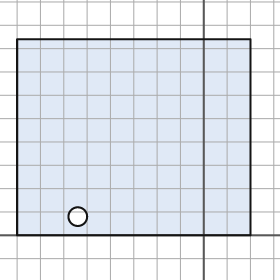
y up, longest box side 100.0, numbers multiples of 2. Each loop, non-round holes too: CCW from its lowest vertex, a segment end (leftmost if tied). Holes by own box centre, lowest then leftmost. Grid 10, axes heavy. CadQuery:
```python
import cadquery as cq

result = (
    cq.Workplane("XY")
    .moveTo(-80.0, 0.0)
    .lineTo(20.0, 0.0)
    .lineTo(20.0, 84.0)
    .lineTo(-80.0, 84.0)
    .close()
    .moveTo(-54.0, 8.0)
    .circle(4.0)
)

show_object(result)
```